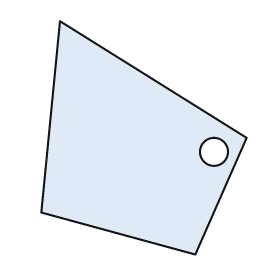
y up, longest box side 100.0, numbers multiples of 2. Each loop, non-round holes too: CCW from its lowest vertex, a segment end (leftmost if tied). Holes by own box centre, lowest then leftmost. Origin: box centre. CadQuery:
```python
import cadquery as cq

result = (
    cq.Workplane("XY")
    .moveTo(22.0, -50.0)
    .lineTo(44.0, 0.0)
    .lineTo(-36.0, 50.0)
    .lineTo(-44.0, -32.0)
    .close()
    .moveTo(30.0, -6.0)
    .circle(6.0)
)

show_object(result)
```